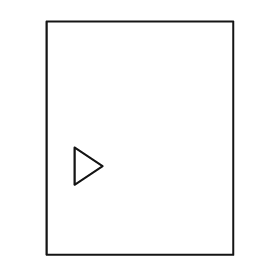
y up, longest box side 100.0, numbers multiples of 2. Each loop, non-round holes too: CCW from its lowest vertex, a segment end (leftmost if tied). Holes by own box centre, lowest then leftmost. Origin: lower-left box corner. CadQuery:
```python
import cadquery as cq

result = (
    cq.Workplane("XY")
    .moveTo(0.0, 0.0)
    .lineTo(80.0, 0.0)
    .lineTo(80.0, 100.0)
    .lineTo(0.0, 100.0)
    .close()
    .moveTo(12.0, 30.0)
    .lineTo(24.0, 38.0)
    .lineTo(12.0, 46.0)
    .close()
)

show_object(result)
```